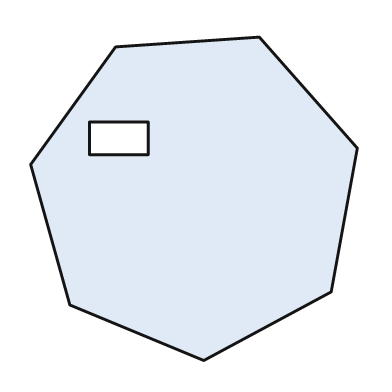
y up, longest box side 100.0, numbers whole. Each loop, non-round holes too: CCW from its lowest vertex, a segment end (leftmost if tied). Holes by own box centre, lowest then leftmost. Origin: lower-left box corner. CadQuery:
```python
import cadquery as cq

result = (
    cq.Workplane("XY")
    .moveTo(53.0, 0.0)
    .lineTo(92.0, 21.0)
    .lineTo(100.0, 65.0)
    .lineTo(70.0, 99.0)
    .lineTo(26.0, 96.0)
    .lineTo(0.0, 60.0)
    .lineTo(12.0, 17.0)
    .close()
    .moveTo(18.0, 63.0)
    .lineTo(36.0, 63.0)
    .lineTo(36.0, 73.0)
    .lineTo(18.0, 73.0)
    .close()
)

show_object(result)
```